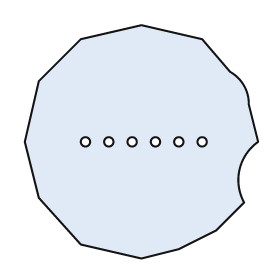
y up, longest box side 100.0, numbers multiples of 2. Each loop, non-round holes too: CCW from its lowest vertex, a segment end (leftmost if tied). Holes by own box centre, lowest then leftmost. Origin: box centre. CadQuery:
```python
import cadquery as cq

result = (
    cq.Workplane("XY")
    .moveTo(0.0, -50.0)
    .lineTo(16.0, -46.0)
    .lineTo(32.0, -38.0)
    .lineTo(44.0, -26.0)
    .threePointArc((42.0, -12.0), (50.0, 0.0))
    .lineTo(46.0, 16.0)
    .threePointArc((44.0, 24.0), (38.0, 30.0))
    .lineTo(26.0, 44.0)
    .lineTo(0.0, 50.0)
    .lineTo(-26.0, 44.0)
    .lineTo(-44.0, 26.0)
    .lineTo(-50.0, 0.0)
    .lineTo(-44.0, -24.0)
    .lineTo(-26.0, -44.0)
    .close()
    .moveTo(-24.0, 0.0)
    .circle(2.0)
    .moveTo(-14.0, 0.0)
    .circle(2.0)
    .moveTo(-4.0, 0.0)
    .circle(2.0)
    .moveTo(6.0, 0.0)
    .circle(2.0)
    .moveTo(16.0, 0.0)
    .circle(2.0)
    .moveTo(26.0, 0.0)
    .circle(2.0)
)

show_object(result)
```